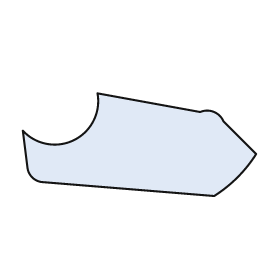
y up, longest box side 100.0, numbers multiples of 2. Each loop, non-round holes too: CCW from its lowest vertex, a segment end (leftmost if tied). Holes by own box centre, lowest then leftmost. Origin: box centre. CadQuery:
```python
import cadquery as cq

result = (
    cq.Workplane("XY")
    .moveTo(32.0, -22.0)
    .threePointArc((42.0, -14.0), (50.0, -4.0))
    .lineTo(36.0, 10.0)
    .threePointArc((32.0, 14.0), (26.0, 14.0))
    .lineTo(-18.0, 22.0)
    .threePointArc((-28.0, 2.0), (-50.0, 6.0))
    .lineTo(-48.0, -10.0)
    .threePointArc((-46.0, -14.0), (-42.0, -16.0))
    .close()
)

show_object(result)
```